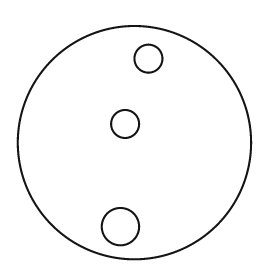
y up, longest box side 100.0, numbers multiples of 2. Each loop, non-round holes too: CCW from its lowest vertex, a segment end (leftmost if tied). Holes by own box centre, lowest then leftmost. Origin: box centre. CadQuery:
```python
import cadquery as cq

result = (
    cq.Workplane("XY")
    .moveTo(0.0, 0.0)
    .circle(50.0)
    .moveTo(-6.0, -36.0)
    .circle(8.0)
    .moveTo(-4.0, 8.0)
    .circle(6.0)
    .moveTo(6.0, 36.0)
    .circle(6.0)
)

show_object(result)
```